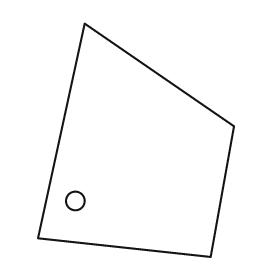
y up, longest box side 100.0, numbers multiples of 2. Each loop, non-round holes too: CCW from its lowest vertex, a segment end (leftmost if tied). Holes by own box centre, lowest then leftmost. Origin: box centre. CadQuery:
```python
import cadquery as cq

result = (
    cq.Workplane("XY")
    .moveTo(32.0, -50.0)
    .lineTo(42.0, 6.0)
    .lineTo(-22.0, 50.0)
    .lineTo(-42.0, -42.0)
    .close()
    .moveTo(-26.0, -26.0)
    .circle(4.0)
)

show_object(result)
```